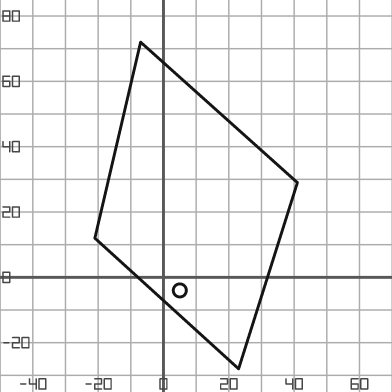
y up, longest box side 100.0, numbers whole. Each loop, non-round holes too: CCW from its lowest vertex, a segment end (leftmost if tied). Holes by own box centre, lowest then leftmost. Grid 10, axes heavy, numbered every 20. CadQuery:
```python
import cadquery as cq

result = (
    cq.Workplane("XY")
    .moveTo(23.0, -28.0)
    .lineTo(41.0, 29.0)
    .lineTo(-7.0, 72.0)
    .lineTo(-21.0, 12.0)
    .close()
    .moveTo(5.0, -4.0)
    .circle(2.0)
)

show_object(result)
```